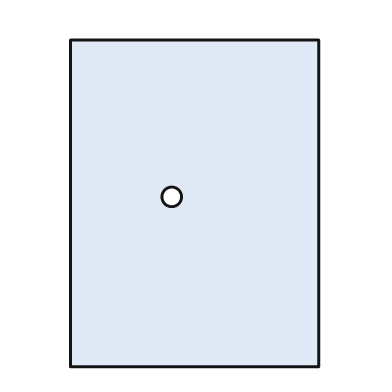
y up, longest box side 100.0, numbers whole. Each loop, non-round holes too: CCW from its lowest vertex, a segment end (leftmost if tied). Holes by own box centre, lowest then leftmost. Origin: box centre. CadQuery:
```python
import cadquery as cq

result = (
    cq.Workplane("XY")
    .moveTo(-38.0, -50.0)
    .lineTo(38.0, -50.0)
    .lineTo(38.0, 50.0)
    .lineTo(-38.0, 50.0)
    .close()
    .moveTo(-7.0, 2.0)
    .circle(3.0)
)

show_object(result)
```